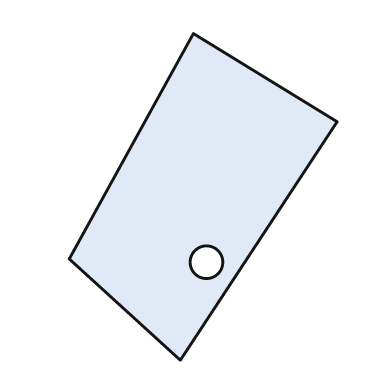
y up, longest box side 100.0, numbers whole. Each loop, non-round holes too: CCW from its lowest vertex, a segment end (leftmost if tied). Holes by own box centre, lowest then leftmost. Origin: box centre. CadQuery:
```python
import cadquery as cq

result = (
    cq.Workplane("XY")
    .moveTo(-7.0, -50.0)
    .lineTo(41.0, 23.0)
    .lineTo(-3.0, 50.0)
    .lineTo(-41.0, -19.0)
    .close()
    .moveTo(1.0, -20.0)
    .circle(5.0)
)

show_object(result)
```